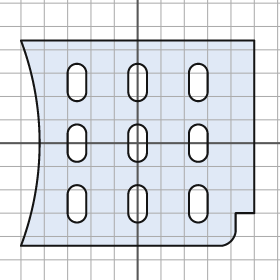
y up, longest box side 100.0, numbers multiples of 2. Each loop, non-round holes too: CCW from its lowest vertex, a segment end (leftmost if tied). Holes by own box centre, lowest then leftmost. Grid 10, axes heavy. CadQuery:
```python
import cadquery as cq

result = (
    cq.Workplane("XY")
    .moveTo(-50.0, -44.0)
    .lineTo(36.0, -44.0)
    .threePointArc((40.0, -42.0), (42.0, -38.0))
    .lineTo(42.0, -30.0)
    .lineTo(50.0, -30.0)
    .lineTo(50.0, 44.0)
    .lineTo(-50.0, 44.0)
    .threePointArc((-42.0, 0.0), (-50.0, -44.0))
    .close()
    .moveTo(-30.0, -30.0)
    .threePointArc((-26.0, -34.0), (-22.0, -30.0))
    .lineTo(-22.0, -22.0)
    .threePointArc((-26.0, -18.0), (-30.0, -22.0))
    .close()
    .moveTo(-4.0, -30.0)
    .threePointArc((0.0, -34.0), (4.0, -30.0))
    .lineTo(4.0, -22.0)
    .threePointArc((0.0, -18.0), (-4.0, -22.0))
    .close()
    .moveTo(22.0, -30.0)
    .threePointArc((26.0, -34.0), (30.0, -30.0))
    .lineTo(30.0, -22.0)
    .threePointArc((26.0, -18.0), (22.0, -22.0))
    .close()
    .moveTo(-30.0, -4.0)
    .threePointArc((-26.0, -8.0), (-22.0, -4.0))
    .lineTo(-22.0, 4.0)
    .threePointArc((-26.0, 8.0), (-30.0, 4.0))
    .close()
    .moveTo(-4.0, -4.0)
    .threePointArc((0.0, -8.0), (4.0, -4.0))
    .lineTo(4.0, 4.0)
    .threePointArc((0.0, 8.0), (-4.0, 4.0))
    .close()
    .moveTo(22.0, -4.0)
    .threePointArc((26.0, -8.0), (30.0, -4.0))
    .lineTo(30.0, 4.0)
    .threePointArc((26.0, 8.0), (22.0, 4.0))
    .close()
    .moveTo(-30.0, 22.0)
    .threePointArc((-26.0, 18.0), (-22.0, 22.0))
    .lineTo(-22.0, 30.0)
    .threePointArc((-26.0, 34.0), (-30.0, 30.0))
    .close()
    .moveTo(-4.0, 22.0)
    .threePointArc((0.0, 18.0), (4.0, 22.0))
    .lineTo(4.0, 30.0)
    .threePointArc((0.0, 34.0), (-4.0, 30.0))
    .close()
    .moveTo(22.0, 22.0)
    .threePointArc((26.0, 18.0), (30.0, 22.0))
    .lineTo(30.0, 30.0)
    .threePointArc((26.0, 34.0), (22.0, 30.0))
    .close()
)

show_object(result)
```